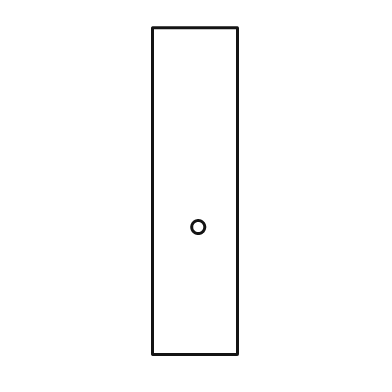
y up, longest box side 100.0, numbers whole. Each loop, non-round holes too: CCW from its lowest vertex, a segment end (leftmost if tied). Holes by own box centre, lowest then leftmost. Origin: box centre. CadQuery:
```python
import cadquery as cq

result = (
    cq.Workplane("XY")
    .moveTo(-13.0, -50.0)
    .lineTo(13.0, -50.0)
    .lineTo(13.0, 50.0)
    .lineTo(-13.0, 50.0)
    .close()
    .moveTo(1.0, -11.0)
    .circle(2.0)
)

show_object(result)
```